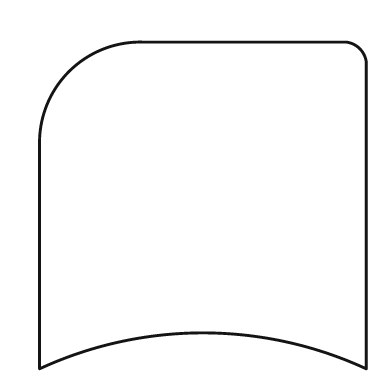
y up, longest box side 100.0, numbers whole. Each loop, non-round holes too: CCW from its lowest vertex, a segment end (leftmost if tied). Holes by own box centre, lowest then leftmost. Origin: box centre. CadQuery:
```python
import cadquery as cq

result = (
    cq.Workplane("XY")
    .moveTo(-50.0, -50.0)
    .threePointArc((0.0, -39.0), (50.0, -50.0))
    .lineTo(50.0, 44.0)
    .threePointArc((48.0, 48.0), (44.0, 50.0))
    .lineTo(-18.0, 50.0)
    .threePointArc((-41.0, 41.0), (-50.0, 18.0))
    .close()
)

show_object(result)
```